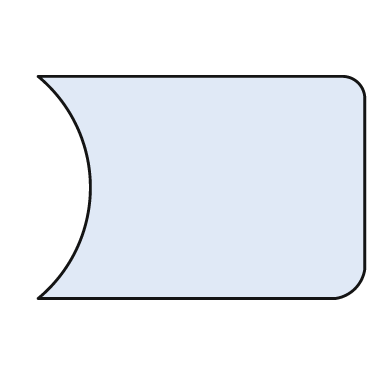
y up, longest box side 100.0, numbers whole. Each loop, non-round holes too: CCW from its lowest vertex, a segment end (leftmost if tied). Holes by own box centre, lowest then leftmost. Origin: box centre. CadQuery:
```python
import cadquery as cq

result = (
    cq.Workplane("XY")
    .moveTo(-50.0, -34.0)
    .lineTo(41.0, -34.0)
    .threePointArc((47.0, -31.0), (50.0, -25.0))
    .lineTo(50.0, 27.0)
    .threePointArc((48.0, 32.0), (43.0, 34.0))
    .lineTo(-50.0, 34.0)
    .threePointArc((-34.0, 0.0), (-50.0, -34.0))
    .close()
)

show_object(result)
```